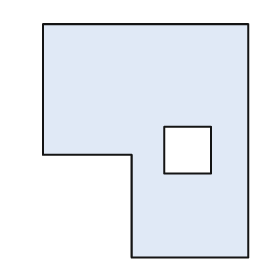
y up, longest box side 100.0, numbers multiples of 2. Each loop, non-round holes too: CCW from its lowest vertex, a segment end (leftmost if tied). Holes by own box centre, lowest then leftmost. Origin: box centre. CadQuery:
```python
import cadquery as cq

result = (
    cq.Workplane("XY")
    .moveTo(-6.0, -50.0)
    .lineTo(44.0, -50.0)
    .lineTo(44.0, 50.0)
    .lineTo(-44.0, 50.0)
    .lineTo(-44.0, -6.0)
    .lineTo(-6.0, -6.0)
    .close()
    .moveTo(8.0, -14.0)
    .lineTo(28.0, -14.0)
    .lineTo(28.0, 6.0)
    .lineTo(8.0, 6.0)
    .close()
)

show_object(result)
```